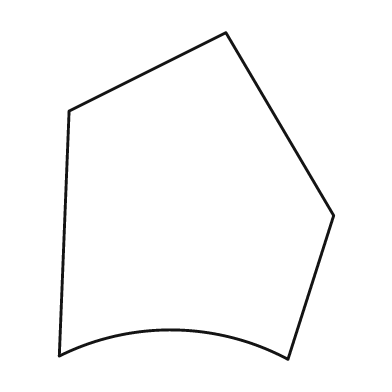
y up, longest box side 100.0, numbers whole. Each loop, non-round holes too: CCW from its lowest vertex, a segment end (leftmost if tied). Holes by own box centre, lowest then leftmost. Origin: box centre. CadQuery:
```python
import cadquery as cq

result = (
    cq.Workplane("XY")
    .moveTo(28.0, -50.0)
    .lineTo(42.0, -6.0)
    .lineTo(9.0, 50.0)
    .lineTo(-39.0, 26.0)
    .lineTo(-42.0, -49.0)
    .threePointArc((-7.0, -41.0), (28.0, -50.0))
    .close()
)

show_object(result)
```